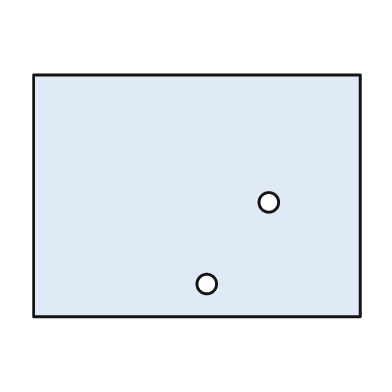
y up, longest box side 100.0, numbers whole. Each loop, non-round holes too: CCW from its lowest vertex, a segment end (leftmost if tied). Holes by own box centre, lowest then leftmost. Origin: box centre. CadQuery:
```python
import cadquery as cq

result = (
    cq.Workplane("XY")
    .moveTo(-50.0, -37.0)
    .lineTo(50.0, -37.0)
    .lineTo(50.0, 37.0)
    .lineTo(-50.0, 37.0)
    .close()
    .moveTo(3.0, -27.0)
    .circle(3.0)
    .moveTo(22.0, -2.0)
    .circle(3.0)
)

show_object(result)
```